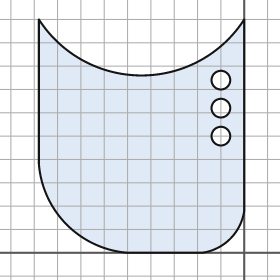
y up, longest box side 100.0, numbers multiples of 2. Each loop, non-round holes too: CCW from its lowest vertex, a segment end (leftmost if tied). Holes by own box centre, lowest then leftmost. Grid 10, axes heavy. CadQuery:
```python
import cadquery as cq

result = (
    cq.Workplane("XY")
    .moveTo(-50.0, 0.0)
    .lineTo(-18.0, 0.0)
    .threePointArc((-6.0, 6.0), (0.0, 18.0))
    .lineTo(0.0, 100.0)
    .threePointArc((-44.0, 76.0), (-88.0, 100.0))
    .lineTo(-88.0, 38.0)
    .threePointArc((-76.0, 12.0), (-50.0, 0.0))
    .close()
    .moveTo(-10.0, 50.0)
    .circle(4.0)
    .moveTo(-10.0, 62.0)
    .circle(4.0)
    .moveTo(-10.0, 74.0)
    .circle(4.0)
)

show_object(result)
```